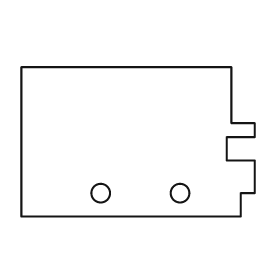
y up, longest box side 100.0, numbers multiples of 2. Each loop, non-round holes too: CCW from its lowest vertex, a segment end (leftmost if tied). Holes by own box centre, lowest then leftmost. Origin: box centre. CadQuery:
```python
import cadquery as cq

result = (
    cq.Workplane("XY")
    .moveTo(-50.0, -32.0)
    .lineTo(44.0, -32.0)
    .lineTo(44.0, -22.0)
    .lineTo(50.0, -22.0)
    .lineTo(50.0, -8.0)
    .lineTo(38.0, -8.0)
    .lineTo(38.0, 2.0)
    .lineTo(50.0, 2.0)
    .lineTo(50.0, 8.0)
    .lineTo(40.0, 8.0)
    .lineTo(40.0, 32.0)
    .lineTo(-50.0, 32.0)
    .close()
    .moveTo(-16.0, -22.0)
    .circle(4.0)
    .moveTo(18.0, -22.0)
    .circle(4.0)
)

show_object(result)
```